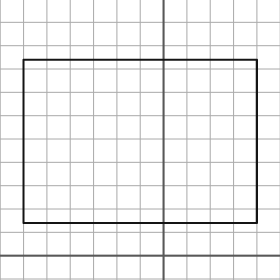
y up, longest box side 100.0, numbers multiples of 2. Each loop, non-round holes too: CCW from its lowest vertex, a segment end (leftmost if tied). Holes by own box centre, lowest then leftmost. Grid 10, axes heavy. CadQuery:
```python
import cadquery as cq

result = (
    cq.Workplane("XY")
    .moveTo(-60.0, 14.0)
    .lineTo(40.0, 14.0)
    .lineTo(40.0, 84.0)
    .lineTo(-60.0, 84.0)
    .close()
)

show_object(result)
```